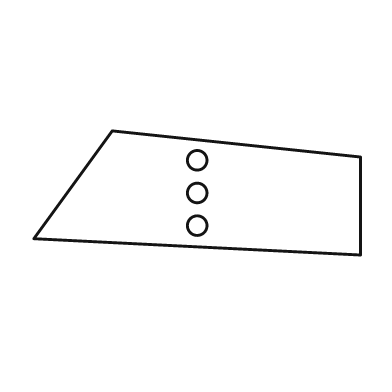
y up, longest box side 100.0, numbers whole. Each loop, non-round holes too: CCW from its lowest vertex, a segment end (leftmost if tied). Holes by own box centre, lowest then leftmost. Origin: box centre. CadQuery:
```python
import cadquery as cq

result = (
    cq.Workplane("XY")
    .moveTo(50.0, -19.0)
    .lineTo(50.0, 11.0)
    .lineTo(-26.0, 19.0)
    .lineTo(-50.0, -14.0)
    .close()
    .moveTo(0.0, -10.0)
    .circle(3.0)
    .moveTo(0.0, 0.0)
    .circle(3.0)
    .moveTo(0.0, 10.0)
    .circle(3.0)
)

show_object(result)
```